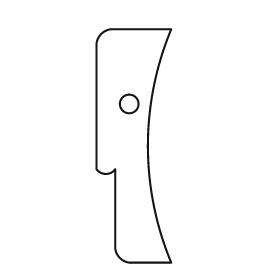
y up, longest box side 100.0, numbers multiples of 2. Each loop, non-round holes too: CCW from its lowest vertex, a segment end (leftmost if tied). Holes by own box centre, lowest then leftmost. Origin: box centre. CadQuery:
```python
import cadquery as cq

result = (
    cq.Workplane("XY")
    .moveTo(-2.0, -50.0)
    .lineTo(16.0, -50.0)
    .threePointArc((6.0, 0.0), (16.0, 50.0))
    .lineTo(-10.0, 50.0)
    .threePointArc((-14.0, 48.0), (-16.0, 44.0))
    .lineTo(-16.0, -10.0)
    .threePointArc((-12.0, -12.0), (-8.0, -10.0))
    .lineTo(-8.0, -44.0)
    .threePointArc((-6.0, -48.0), (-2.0, -50.0))
    .close()
    .moveTo(-2.0, 18.0)
    .circle(4.0)
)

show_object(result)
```